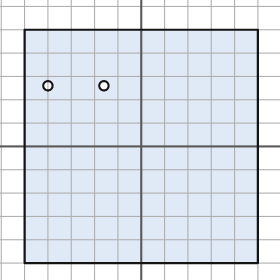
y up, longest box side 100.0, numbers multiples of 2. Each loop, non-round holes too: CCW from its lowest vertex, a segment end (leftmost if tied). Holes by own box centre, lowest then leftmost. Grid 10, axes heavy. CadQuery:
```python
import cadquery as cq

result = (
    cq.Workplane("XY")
    .moveTo(-50.0, -50.0)
    .lineTo(50.0, -50.0)
    .lineTo(50.0, 50.0)
    .lineTo(-50.0, 50.0)
    .close()
    .moveTo(-40.0, 26.0)
    .circle(2.0)
    .moveTo(-16.0, 26.0)
    .circle(2.0)
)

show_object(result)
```